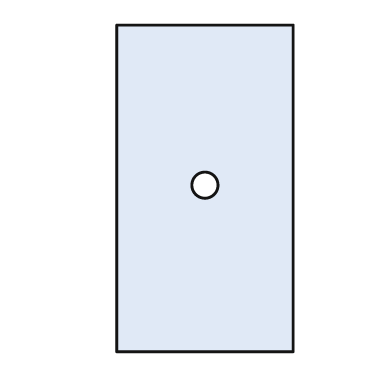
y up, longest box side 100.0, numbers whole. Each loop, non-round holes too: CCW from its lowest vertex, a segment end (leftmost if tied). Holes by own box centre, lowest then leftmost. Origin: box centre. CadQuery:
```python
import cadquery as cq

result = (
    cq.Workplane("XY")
    .moveTo(-27.0, -50.0)
    .lineTo(27.0, -50.0)
    .lineTo(27.0, 50.0)
    .lineTo(-27.0, 50.0)
    .close()
    .moveTo(0.0, 1.0)
    .circle(4.0)
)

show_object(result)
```